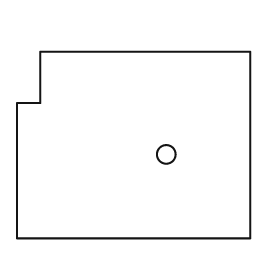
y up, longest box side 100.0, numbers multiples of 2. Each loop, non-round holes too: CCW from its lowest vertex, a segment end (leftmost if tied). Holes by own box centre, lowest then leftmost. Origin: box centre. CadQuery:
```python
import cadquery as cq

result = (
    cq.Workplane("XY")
    .moveTo(-50.0, -40.0)
    .lineTo(50.0, -40.0)
    .lineTo(50.0, 40.0)
    .lineTo(-40.0, 40.0)
    .lineTo(-40.0, 18.0)
    .lineTo(-50.0, 18.0)
    .close()
    .moveTo(14.0, -4.0)
    .circle(4.0)
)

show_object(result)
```